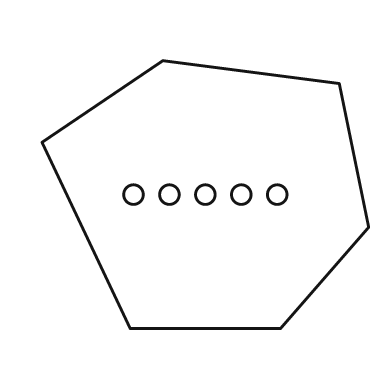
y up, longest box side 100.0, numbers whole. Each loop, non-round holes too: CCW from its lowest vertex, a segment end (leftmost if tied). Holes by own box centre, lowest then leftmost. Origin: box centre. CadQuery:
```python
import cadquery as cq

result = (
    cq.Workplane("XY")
    .moveTo(-23.0, -41.0)
    .lineTo(23.0, -41.0)
    .lineTo(50.0, -10.0)
    .lineTo(41.0, 34.0)
    .lineTo(-13.0, 41.0)
    .lineTo(-50.0, 16.0)
    .close()
    .moveTo(-22.0, 0.0)
    .circle(3.0)
    .moveTo(-11.0, 0.0)
    .circle(3.0)
    .moveTo(0.0, 0.0)
    .circle(3.0)
    .moveTo(11.0, 0.0)
    .circle(3.0)
    .moveTo(22.0, 0.0)
    .circle(3.0)
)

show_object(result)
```